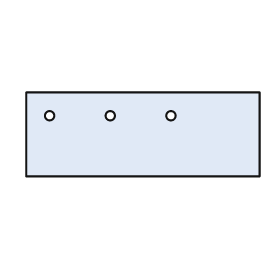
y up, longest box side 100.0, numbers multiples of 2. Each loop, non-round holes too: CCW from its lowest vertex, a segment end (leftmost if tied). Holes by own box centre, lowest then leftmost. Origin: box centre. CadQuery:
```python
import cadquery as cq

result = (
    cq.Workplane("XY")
    .moveTo(-50.0, -18.0)
    .lineTo(50.0, -18.0)
    .lineTo(50.0, 18.0)
    .lineTo(-50.0, 18.0)
    .close()
    .moveTo(-40.0, 8.0)
    .circle(2.0)
    .moveTo(-14.0, 8.0)
    .circle(2.0)
    .moveTo(12.0, 8.0)
    .circle(2.0)
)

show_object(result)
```